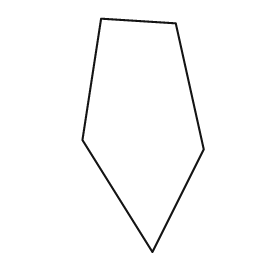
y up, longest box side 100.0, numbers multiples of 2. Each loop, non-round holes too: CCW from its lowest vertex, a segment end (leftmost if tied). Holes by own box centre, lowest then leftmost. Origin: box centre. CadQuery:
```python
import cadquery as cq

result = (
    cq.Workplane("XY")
    .moveTo(4.0, -50.0)
    .lineTo(26.0, -6.0)
    .lineTo(14.0, 48.0)
    .lineTo(-18.0, 50.0)
    .lineTo(-26.0, -2.0)
    .close()
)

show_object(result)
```